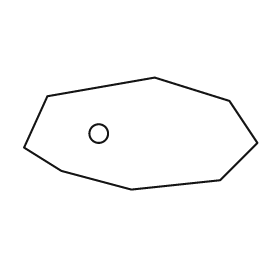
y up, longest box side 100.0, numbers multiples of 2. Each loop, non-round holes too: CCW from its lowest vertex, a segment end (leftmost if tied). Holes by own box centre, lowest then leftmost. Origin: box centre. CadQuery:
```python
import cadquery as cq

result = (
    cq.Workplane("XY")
    .moveTo(-4.0, -24.0)
    .lineTo(34.0, -20.0)
    .lineTo(50.0, -4.0)
    .lineTo(38.0, 14.0)
    .lineTo(6.0, 24.0)
    .lineTo(-40.0, 16.0)
    .lineTo(-50.0, -6.0)
    .lineTo(-34.0, -16.0)
    .close()
    .moveTo(-18.0, 0.0)
    .circle(4.0)
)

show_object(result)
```